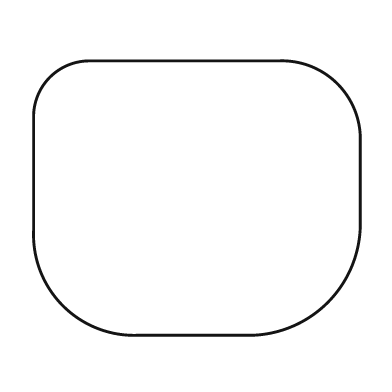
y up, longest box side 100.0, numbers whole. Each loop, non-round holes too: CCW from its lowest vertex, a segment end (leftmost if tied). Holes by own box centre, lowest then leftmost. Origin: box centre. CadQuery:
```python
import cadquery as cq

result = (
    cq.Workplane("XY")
    .moveTo(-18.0, -42.0)
    .lineTo(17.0, -42.0)
    .threePointArc((40.0, -32.0), (50.0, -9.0))
    .lineTo(50.0, 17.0)
    .threePointArc((43.0, 35.0), (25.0, 42.0))
    .lineTo(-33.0, 42.0)
    .threePointArc((-45.0, 37.0), (-50.0, 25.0))
    .lineTo(-50.0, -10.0)
    .threePointArc((-41.0, -33.0), (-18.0, -42.0))
    .close()
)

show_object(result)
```